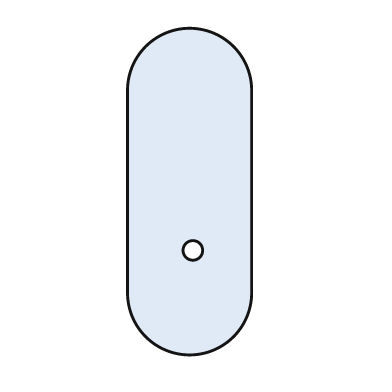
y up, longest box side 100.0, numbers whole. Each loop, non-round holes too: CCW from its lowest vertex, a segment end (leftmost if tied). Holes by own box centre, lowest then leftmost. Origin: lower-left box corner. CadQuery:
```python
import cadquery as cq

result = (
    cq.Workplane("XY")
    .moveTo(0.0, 19.0)
    .threePointArc((19.0, 0.0), (38.0, 19.0))
    .lineTo(38.0, 81.0)
    .threePointArc((19.0, 100.0), (0.0, 81.0))
    .close()
    .moveTo(20.0, 32.0)
    .circle(3.0)
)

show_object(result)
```